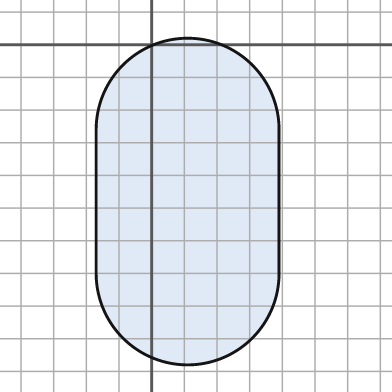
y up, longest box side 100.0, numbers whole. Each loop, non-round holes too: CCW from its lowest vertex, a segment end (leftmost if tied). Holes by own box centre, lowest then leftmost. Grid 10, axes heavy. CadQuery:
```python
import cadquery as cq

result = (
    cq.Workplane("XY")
    .moveTo(-17.0, -70.0)
    .threePointArc((11.0, -98.0), (39.0, -70.0))
    .lineTo(39.0, -26.0)
    .threePointArc((11.0, 2.0), (-17.0, -26.0))
    .close()
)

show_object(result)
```